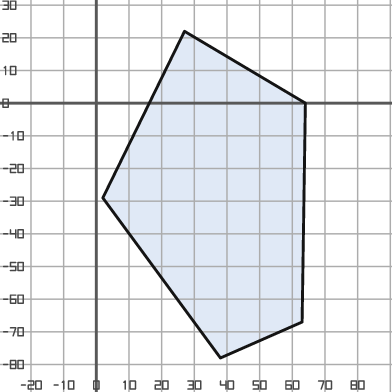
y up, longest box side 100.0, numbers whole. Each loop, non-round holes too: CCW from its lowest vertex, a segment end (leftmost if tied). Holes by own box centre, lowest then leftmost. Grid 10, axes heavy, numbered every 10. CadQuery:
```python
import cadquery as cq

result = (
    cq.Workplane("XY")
    .moveTo(38.0, -78.0)
    .lineTo(63.0, -67.0)
    .lineTo(64.0, 0.0)
    .lineTo(27.0, 22.0)
    .lineTo(2.0, -29.0)
    .close()
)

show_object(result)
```